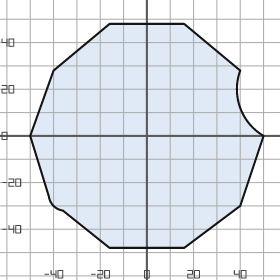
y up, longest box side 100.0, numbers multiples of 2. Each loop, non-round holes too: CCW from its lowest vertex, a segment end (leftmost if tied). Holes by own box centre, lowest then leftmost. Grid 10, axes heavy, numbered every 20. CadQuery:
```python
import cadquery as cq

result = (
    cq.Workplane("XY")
    .moveTo(-16.0, -48.0)
    .lineTo(16.0, -48.0)
    .lineTo(40.0, -30.0)
    .lineTo(50.0, 0.0)
    .threePointArc((40.0, 12.0), (40.0, 28.0))
    .lineTo(16.0, 48.0)
    .lineTo(-16.0, 48.0)
    .lineTo(-40.0, 28.0)
    .lineTo(-50.0, 0.0)
    .lineTo(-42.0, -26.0)
    .threePointArc((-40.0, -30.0), (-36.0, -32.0))
    .close()
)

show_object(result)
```